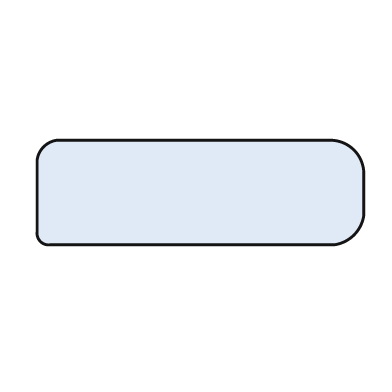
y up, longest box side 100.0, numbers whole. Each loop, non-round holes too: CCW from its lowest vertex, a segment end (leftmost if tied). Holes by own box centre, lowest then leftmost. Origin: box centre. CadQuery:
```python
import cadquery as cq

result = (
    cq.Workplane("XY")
    .moveTo(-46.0, -16.0)
    .lineTo(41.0, -16.0)
    .threePointArc((47.0, -13.0), (50.0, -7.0))
    .lineTo(50.0, 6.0)
    .threePointArc((47.0, 13.0), (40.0, 16.0))
    .lineTo(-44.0, 16.0)
    .threePointArc((-48.0, 14.0), (-50.0, 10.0))
    .lineTo(-50.0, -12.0)
    .threePointArc((-49.0, -15.0), (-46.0, -16.0))
    .close()
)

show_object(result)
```